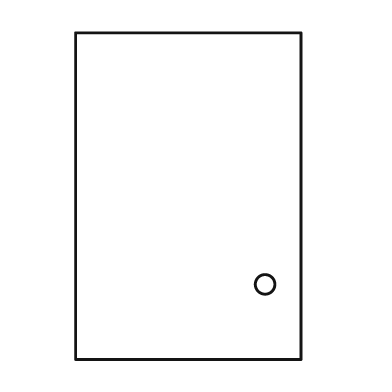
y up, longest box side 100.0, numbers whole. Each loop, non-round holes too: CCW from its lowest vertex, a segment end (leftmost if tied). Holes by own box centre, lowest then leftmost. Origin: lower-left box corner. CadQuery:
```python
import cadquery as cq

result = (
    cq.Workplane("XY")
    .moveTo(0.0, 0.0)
    .lineTo(69.0, 0.0)
    .lineTo(69.0, 100.0)
    .lineTo(0.0, 100.0)
    .close()
    .moveTo(58.0, 23.0)
    .circle(3.0)
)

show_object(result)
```